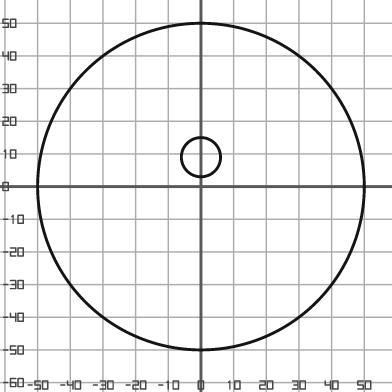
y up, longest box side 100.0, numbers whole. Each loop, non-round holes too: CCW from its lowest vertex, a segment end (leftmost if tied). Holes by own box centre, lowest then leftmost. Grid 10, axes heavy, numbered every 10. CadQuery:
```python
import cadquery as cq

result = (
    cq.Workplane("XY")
    .moveTo(0.0, 0.0)
    .circle(50.0)
    .moveTo(0.0, 9.0)
    .circle(6.0)
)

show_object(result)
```